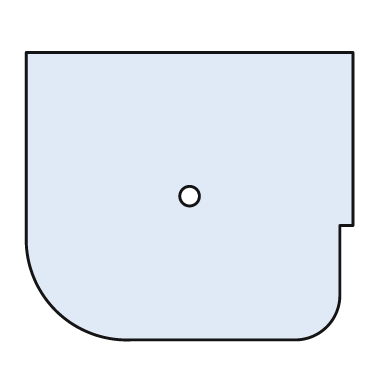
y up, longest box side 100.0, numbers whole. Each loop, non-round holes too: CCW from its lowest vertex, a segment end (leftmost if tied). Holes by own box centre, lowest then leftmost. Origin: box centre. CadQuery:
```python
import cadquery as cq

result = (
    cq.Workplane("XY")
    .moveTo(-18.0, -44.0)
    .lineTo(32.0, -44.0)
    .threePointArc((42.0, -40.0), (46.0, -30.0))
    .lineTo(46.0, -9.0)
    .lineTo(50.0, -9.0)
    .lineTo(50.0, 44.0)
    .lineTo(-50.0, 44.0)
    .lineTo(-50.0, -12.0)
    .threePointArc((-41.0, -35.0), (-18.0, -44.0))
    .close()
    .moveTo(0.0, 0.0)
    .circle(3.0)
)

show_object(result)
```